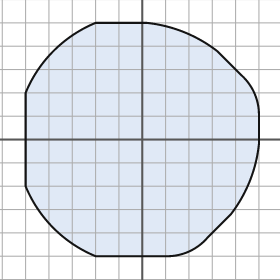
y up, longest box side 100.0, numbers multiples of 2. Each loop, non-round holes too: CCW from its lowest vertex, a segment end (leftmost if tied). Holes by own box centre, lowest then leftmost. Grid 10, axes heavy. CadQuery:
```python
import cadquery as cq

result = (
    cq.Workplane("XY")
    .moveTo(-20.0, -50.0)
    .lineTo(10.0, -50.0)
    .threePointArc((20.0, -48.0), (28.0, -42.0))
    .lineTo(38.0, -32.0)
    .threePointArc((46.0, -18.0), (50.0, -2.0))
    .lineTo(50.0, 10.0)
    .threePointArc((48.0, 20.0), (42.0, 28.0))
    .lineTo(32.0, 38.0)
    .threePointArc((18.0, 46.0), (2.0, 50.0))
    .lineTo(-20.0, 50.0)
    .threePointArc((-38.0, 38.0), (-50.0, 20.0))
    .lineTo(-50.0, -20.0)
    .threePointArc((-38.0, -38.0), (-20.0, -50.0))
    .close()
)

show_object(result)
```